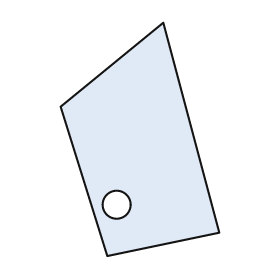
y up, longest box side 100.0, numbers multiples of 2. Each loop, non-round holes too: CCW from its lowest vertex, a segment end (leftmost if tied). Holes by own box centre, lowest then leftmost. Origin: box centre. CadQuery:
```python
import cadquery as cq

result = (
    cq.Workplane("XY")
    .moveTo(-14.0, -50.0)
    .lineTo(34.0, -40.0)
    .lineTo(10.0, 50.0)
    .lineTo(-34.0, 14.0)
    .close()
    .moveTo(-10.0, -28.0)
    .circle(6.0)
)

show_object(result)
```